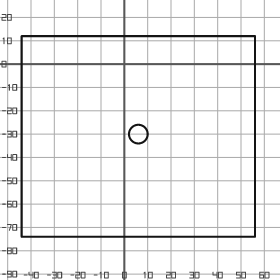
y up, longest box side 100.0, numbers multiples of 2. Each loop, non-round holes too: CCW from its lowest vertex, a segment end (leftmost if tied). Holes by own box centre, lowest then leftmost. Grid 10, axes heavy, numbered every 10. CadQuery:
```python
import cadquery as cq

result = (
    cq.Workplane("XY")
    .moveTo(-44.0, -74.0)
    .lineTo(56.0, -74.0)
    .lineTo(56.0, 12.0)
    .lineTo(-44.0, 12.0)
    .close()
    .moveTo(6.0, -30.0)
    .circle(4.0)
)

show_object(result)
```